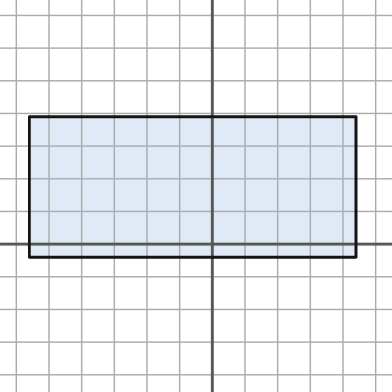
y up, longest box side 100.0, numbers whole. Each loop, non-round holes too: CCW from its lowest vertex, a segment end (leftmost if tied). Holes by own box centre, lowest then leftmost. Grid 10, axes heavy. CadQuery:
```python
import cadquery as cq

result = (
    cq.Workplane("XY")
    .moveTo(-56.0, -4.0)
    .lineTo(44.0, -4.0)
    .lineTo(44.0, 39.0)
    .lineTo(-56.0, 39.0)
    .close()
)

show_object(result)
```